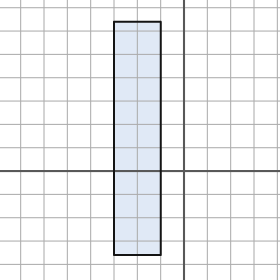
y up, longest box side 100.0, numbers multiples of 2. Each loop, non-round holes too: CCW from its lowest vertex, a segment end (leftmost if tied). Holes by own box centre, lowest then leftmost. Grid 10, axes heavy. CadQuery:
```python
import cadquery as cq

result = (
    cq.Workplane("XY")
    .moveTo(-30.0, -36.0)
    .lineTo(-10.0, -36.0)
    .lineTo(-10.0, 64.0)
    .lineTo(-30.0, 64.0)
    .close()
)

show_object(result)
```